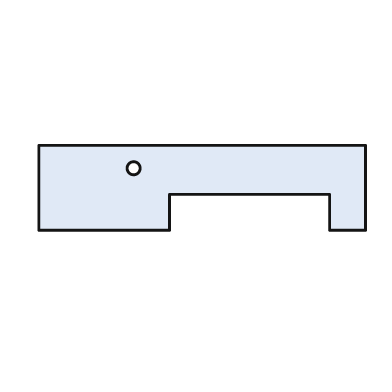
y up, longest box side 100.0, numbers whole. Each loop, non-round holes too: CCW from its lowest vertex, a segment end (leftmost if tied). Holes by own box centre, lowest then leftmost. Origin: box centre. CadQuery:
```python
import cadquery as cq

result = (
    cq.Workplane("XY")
    .moveTo(-50.0, -13.0)
    .lineTo(-10.0, -13.0)
    .lineTo(-10.0, -2.0)
    .lineTo(39.0, -2.0)
    .lineTo(39.0, -13.0)
    .lineTo(50.0, -13.0)
    .lineTo(50.0, 13.0)
    .lineTo(-50.0, 13.0)
    .close()
    .moveTo(-21.0, 6.0)
    .circle(2.0)
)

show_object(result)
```